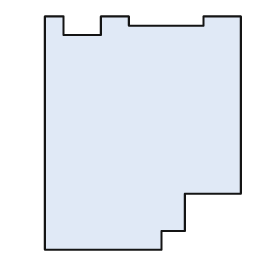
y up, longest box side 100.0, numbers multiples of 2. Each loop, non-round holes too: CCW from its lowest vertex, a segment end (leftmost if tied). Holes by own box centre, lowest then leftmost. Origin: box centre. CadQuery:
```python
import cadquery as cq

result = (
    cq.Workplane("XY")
    .moveTo(-42.0, -50.0)
    .lineTo(8.0, -50.0)
    .lineTo(8.0, -42.0)
    .lineTo(18.0, -42.0)
    .lineTo(18.0, -26.0)
    .lineTo(42.0, -26.0)
    .lineTo(42.0, 50.0)
    .lineTo(26.0, 50.0)
    .lineTo(26.0, 46.0)
    .lineTo(-6.0, 46.0)
    .lineTo(-6.0, 50.0)
    .lineTo(-18.0, 50.0)
    .lineTo(-18.0, 42.0)
    .lineTo(-34.0, 42.0)
    .lineTo(-34.0, 50.0)
    .lineTo(-42.0, 50.0)
    .close()
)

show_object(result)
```